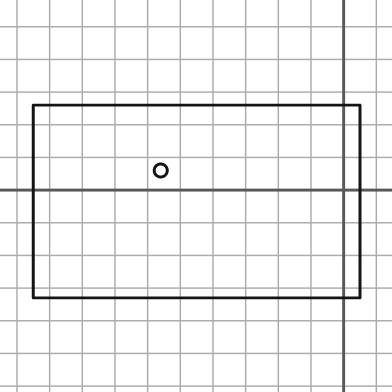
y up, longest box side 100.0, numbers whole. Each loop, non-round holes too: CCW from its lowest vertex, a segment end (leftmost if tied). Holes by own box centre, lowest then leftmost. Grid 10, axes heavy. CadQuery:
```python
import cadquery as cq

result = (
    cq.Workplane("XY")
    .moveTo(-95.0, -33.0)
    .lineTo(5.0, -33.0)
    .lineTo(5.0, 26.0)
    .lineTo(-95.0, 26.0)
    .close()
    .moveTo(-56.0, 6.0)
    .circle(2.0)
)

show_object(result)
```